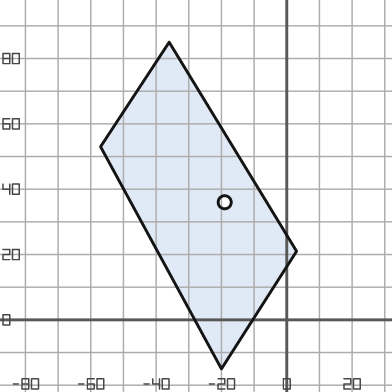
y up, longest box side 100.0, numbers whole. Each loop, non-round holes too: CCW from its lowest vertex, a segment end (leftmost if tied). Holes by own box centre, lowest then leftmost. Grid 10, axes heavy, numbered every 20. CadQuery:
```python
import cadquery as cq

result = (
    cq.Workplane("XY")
    .moveTo(-20.0, -15.0)
    .lineTo(3.0, 21.0)
    .lineTo(-36.0, 85.0)
    .lineTo(-57.0, 53.0)
    .close()
    .moveTo(-19.0, 36.0)
    .circle(2.0)
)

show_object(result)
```